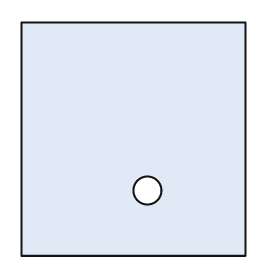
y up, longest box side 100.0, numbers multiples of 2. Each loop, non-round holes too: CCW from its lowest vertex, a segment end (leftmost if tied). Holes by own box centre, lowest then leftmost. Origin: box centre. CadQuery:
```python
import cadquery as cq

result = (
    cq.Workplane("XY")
    .moveTo(-48.0, -50.0)
    .lineTo(48.0, -50.0)
    .lineTo(48.0, 50.0)
    .lineTo(-48.0, 50.0)
    .close()
    .moveTo(6.0, -22.0)
    .circle(6.0)
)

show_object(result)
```